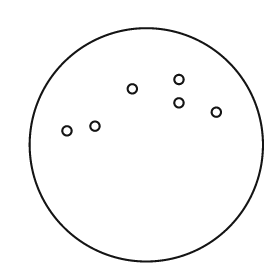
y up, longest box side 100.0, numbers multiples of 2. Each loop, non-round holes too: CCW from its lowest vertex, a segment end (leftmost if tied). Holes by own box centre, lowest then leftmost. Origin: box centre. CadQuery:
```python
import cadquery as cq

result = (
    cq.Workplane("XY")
    .moveTo(0.0, 0.0)
    .circle(50.0)
    .moveTo(-34.0, 6.0)
    .circle(2.0)
    .moveTo(-22.0, 8.0)
    .circle(2.0)
    .moveTo(30.0, 14.0)
    .circle(2.0)
    .moveTo(14.0, 18.0)
    .circle(2.0)
    .moveTo(-6.0, 24.0)
    .circle(2.0)
    .moveTo(14.0, 28.0)
    .circle(2.0)
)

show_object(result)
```